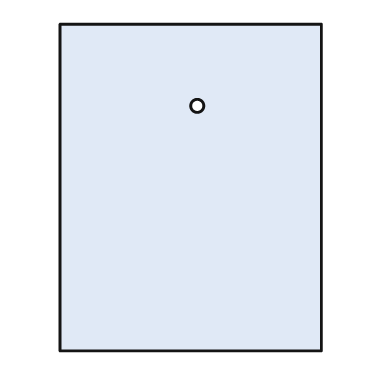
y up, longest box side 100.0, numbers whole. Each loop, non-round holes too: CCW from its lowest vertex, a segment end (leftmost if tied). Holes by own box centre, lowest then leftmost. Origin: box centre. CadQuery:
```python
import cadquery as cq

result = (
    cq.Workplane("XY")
    .moveTo(-40.0, -50.0)
    .lineTo(40.0, -50.0)
    .lineTo(40.0, 50.0)
    .lineTo(-40.0, 50.0)
    .close()
    .moveTo(2.0, 25.0)
    .circle(2.0)
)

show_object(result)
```